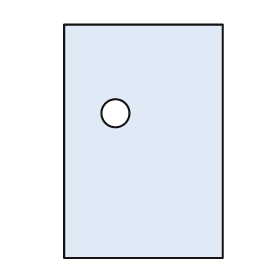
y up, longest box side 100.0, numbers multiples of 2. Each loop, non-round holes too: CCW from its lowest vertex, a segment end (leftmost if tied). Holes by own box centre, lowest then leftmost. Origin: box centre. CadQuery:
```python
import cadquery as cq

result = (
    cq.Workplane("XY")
    .moveTo(-34.0, -50.0)
    .lineTo(34.0, -50.0)
    .lineTo(34.0, 50.0)
    .lineTo(-34.0, 50.0)
    .close()
    .moveTo(-12.0, 12.0)
    .circle(6.0)
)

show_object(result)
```